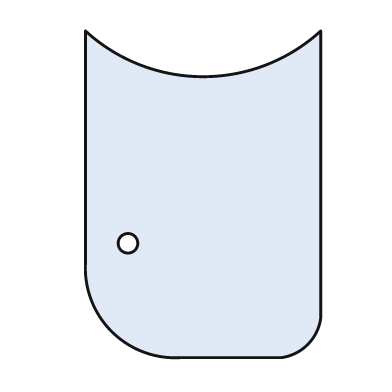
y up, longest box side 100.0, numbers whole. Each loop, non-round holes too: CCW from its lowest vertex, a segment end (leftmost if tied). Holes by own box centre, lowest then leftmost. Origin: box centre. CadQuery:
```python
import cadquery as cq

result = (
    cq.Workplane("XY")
    .moveTo(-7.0, -50.0)
    .lineTo(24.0, -50.0)
    .threePointArc((32.0, -46.0), (36.0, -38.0))
    .lineTo(36.0, 50.0)
    .threePointArc((0.0, 36.0), (-36.0, 50.0))
    .lineTo(-36.0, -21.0)
    .threePointArc((-28.0, -42.0), (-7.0, -50.0))
    .close()
    .moveTo(-23.0, -15.0)
    .circle(3.0)
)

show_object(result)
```